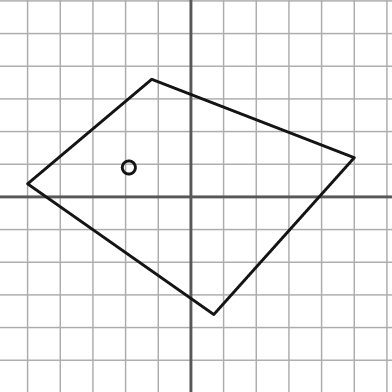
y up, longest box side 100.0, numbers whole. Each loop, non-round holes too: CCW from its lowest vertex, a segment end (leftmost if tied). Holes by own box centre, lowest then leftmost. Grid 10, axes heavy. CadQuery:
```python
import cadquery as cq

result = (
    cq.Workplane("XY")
    .moveTo(7.0, -36.0)
    .lineTo(50.0, 12.0)
    .lineTo(-12.0, 36.0)
    .lineTo(-50.0, 4.0)
    .close()
    .moveTo(-19.0, 9.0)
    .circle(2.0)
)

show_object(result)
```